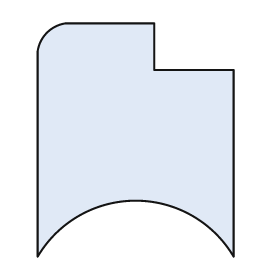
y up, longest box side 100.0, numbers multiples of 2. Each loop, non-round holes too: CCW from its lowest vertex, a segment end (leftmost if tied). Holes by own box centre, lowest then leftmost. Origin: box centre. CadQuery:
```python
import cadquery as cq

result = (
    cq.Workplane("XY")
    .moveTo(-42.0, -50.0)
    .threePointArc((0.0, -26.0), (42.0, -50.0))
    .lineTo(42.0, 30.0)
    .lineTo(8.0, 30.0)
    .lineTo(8.0, 50.0)
    .lineTo(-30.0, 50.0)
    .threePointArc((-38.0, 46.0), (-42.0, 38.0))
    .close()
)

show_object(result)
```